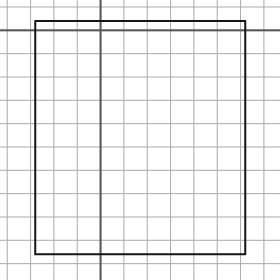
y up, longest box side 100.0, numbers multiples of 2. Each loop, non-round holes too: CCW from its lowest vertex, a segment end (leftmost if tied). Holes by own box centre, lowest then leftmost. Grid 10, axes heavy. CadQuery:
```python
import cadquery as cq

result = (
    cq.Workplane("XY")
    .moveTo(-28.0, -96.0)
    .lineTo(62.0, -96.0)
    .lineTo(62.0, 4.0)
    .lineTo(-28.0, 4.0)
    .close()
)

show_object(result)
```